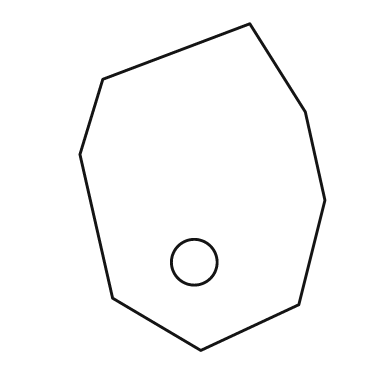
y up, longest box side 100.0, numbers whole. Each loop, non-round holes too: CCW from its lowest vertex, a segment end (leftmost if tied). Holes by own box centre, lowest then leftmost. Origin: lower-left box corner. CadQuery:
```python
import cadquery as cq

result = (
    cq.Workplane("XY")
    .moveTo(37.0, 0.0)
    .lineTo(67.0, 14.0)
    .lineTo(75.0, 46.0)
    .lineTo(69.0, 73.0)
    .lineTo(52.0, 100.0)
    .lineTo(7.0, 83.0)
    .lineTo(0.0, 60.0)
    .lineTo(10.0, 16.0)
    .close()
    .moveTo(35.0, 27.0)
    .circle(7.0)
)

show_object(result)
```